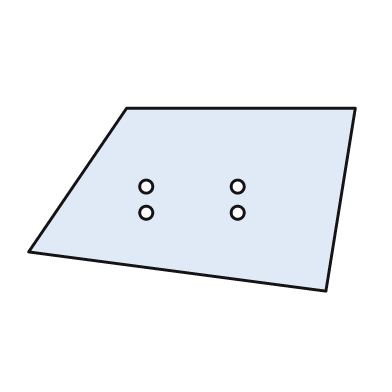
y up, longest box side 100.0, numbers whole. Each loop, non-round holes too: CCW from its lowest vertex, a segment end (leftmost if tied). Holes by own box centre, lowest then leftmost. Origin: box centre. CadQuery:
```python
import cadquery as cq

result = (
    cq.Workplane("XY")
    .moveTo(41.0, -28.0)
    .lineTo(50.0, 28.0)
    .lineTo(-20.0, 28.0)
    .lineTo(-50.0, -16.0)
    .close()
    .moveTo(-14.0, -4.0)
    .circle(2.0)
    .moveTo(14.0, -4.0)
    .circle(2.0)
    .moveTo(-14.0, 4.0)
    .circle(2.0)
    .moveTo(14.0, 4.0)
    .circle(2.0)
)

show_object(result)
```